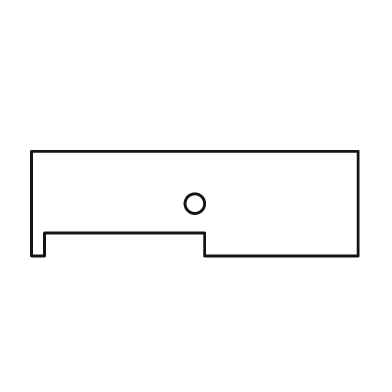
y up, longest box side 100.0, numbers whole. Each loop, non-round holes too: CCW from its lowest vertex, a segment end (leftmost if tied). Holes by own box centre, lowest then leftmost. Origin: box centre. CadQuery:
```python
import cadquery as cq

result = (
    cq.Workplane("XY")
    .moveTo(-50.0, -16.0)
    .lineTo(-46.0, -16.0)
    .lineTo(-46.0, -9.0)
    .lineTo(3.0, -9.0)
    .lineTo(3.0, -16.0)
    .lineTo(50.0, -16.0)
    .lineTo(50.0, 16.0)
    .lineTo(-50.0, 16.0)
    .close()
    .moveTo(0.0, 0.0)
    .circle(3.0)
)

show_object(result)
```